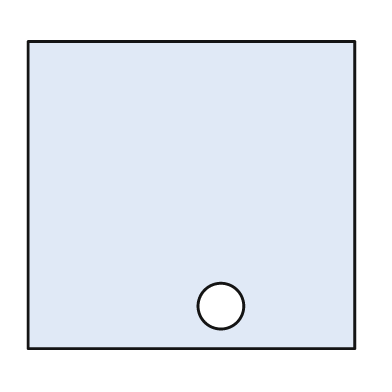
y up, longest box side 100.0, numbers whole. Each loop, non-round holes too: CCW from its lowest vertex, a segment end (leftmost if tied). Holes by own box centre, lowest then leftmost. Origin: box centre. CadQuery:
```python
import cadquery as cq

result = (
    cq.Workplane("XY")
    .moveTo(-50.0, -47.0)
    .lineTo(50.0, -47.0)
    .lineTo(50.0, 47.0)
    .lineTo(-50.0, 47.0)
    .close()
    .moveTo(9.0, -34.0)
    .circle(7.0)
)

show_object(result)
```